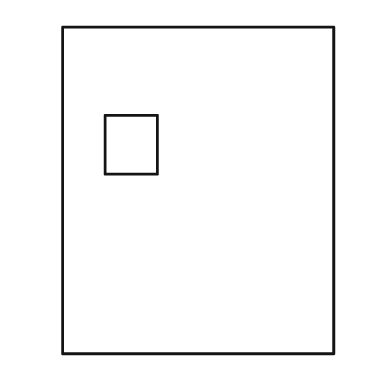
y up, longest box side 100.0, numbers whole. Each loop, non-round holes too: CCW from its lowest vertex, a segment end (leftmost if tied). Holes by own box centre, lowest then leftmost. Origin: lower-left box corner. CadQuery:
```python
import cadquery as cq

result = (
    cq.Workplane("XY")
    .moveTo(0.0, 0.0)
    .lineTo(83.0, 0.0)
    .lineTo(83.0, 100.0)
    .lineTo(0.0, 100.0)
    .close()
    .moveTo(13.0, 55.0)
    .lineTo(29.0, 55.0)
    .lineTo(29.0, 73.0)
    .lineTo(13.0, 73.0)
    .close()
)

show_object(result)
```